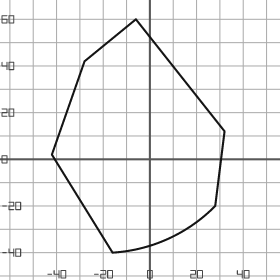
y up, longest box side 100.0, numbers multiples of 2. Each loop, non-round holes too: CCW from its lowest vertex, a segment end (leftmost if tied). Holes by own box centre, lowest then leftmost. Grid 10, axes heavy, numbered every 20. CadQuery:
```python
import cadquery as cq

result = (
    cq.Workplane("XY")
    .moveTo(-16.0, -40.0)
    .threePointArc((8.0, -34.0), (28.0, -20.0))
    .lineTo(32.0, 12.0)
    .lineTo(-6.0, 60.0)
    .lineTo(-28.0, 42.0)
    .lineTo(-42.0, 2.0)
    .close()
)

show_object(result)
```